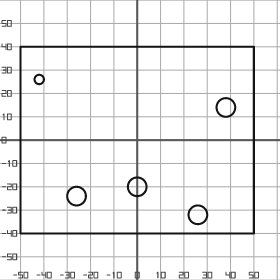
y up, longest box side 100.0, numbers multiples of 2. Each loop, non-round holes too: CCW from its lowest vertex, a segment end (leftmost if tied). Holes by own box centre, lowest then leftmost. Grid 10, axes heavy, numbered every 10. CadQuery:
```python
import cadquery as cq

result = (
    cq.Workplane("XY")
    .moveTo(-50.0, -40.0)
    .lineTo(50.0, -40.0)
    .lineTo(50.0, 40.0)
    .lineTo(-50.0, 40.0)
    .close()
    .moveTo(26.0, -32.0)
    .circle(4.0)
    .moveTo(-26.0, -24.0)
    .circle(4.0)
    .moveTo(0.0, -20.0)
    .circle(4.0)
    .moveTo(38.0, 14.0)
    .circle(4.0)
    .moveTo(-42.0, 26.0)
    .circle(2.0)
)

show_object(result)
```